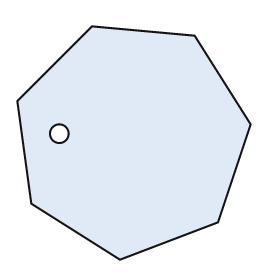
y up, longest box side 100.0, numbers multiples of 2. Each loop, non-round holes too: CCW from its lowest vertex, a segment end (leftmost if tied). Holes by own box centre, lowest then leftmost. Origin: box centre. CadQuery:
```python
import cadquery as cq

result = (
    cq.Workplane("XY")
    .moveTo(-6.0, -50.0)
    .lineTo(36.0, -34.0)
    .lineTo(50.0, 8.0)
    .lineTo(26.0, 46.0)
    .lineTo(-18.0, 50.0)
    .lineTo(-50.0, 18.0)
    .lineTo(-44.0, -26.0)
    .close()
    .moveTo(-32.0, 4.0)
    .circle(4.0)
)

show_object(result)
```